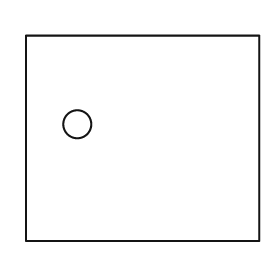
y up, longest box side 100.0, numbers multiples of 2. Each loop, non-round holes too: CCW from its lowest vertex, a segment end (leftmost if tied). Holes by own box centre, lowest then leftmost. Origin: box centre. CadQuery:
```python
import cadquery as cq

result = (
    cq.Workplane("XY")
    .moveTo(-50.0, -44.0)
    .lineTo(50.0, -44.0)
    .lineTo(50.0, 44.0)
    .lineTo(-50.0, 44.0)
    .close()
    .moveTo(-28.0, 6.0)
    .circle(6.0)
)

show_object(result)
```